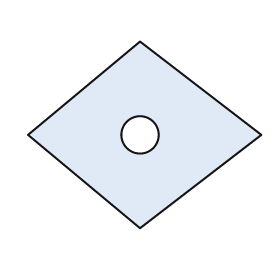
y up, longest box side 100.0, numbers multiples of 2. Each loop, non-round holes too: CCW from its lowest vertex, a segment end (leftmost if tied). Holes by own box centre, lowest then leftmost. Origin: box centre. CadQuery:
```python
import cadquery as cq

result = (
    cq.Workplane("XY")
    .moveTo(-2.0, -40.0)
    .lineTo(50.0, 0.0)
    .lineTo(-2.0, 40.0)
    .lineTo(-50.0, 0.0)
    .close()
    .moveTo(-2.0, 0.0)
    .circle(8.0)
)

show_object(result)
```